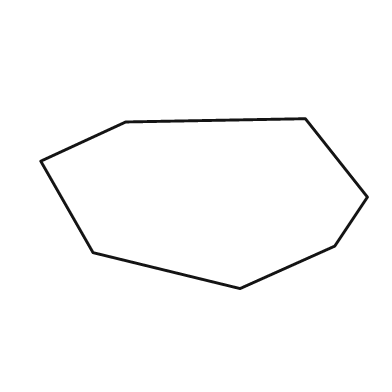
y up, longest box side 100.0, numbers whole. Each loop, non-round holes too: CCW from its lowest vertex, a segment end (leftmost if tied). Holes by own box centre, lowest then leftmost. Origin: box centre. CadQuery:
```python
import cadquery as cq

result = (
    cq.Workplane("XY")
    .moveTo(11.0, -26.0)
    .lineTo(40.0, -13.0)
    .lineTo(50.0, 2.0)
    .lineTo(31.0, 26.0)
    .lineTo(-24.0, 25.0)
    .lineTo(-50.0, 13.0)
    .lineTo(-34.0, -15.0)
    .close()
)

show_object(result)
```